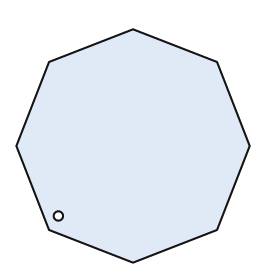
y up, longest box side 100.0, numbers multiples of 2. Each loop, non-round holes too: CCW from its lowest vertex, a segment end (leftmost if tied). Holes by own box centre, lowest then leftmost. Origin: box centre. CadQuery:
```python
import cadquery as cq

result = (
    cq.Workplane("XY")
    .moveTo(0.0, -50.0)
    .lineTo(36.0, -36.0)
    .lineTo(50.0, 0.0)
    .lineTo(36.0, 36.0)
    .lineTo(0.0, 50.0)
    .lineTo(-36.0, 36.0)
    .lineTo(-50.0, 0.0)
    .lineTo(-36.0, -36.0)
    .close()
    .moveTo(-32.0, -30.0)
    .circle(2.0)
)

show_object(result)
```